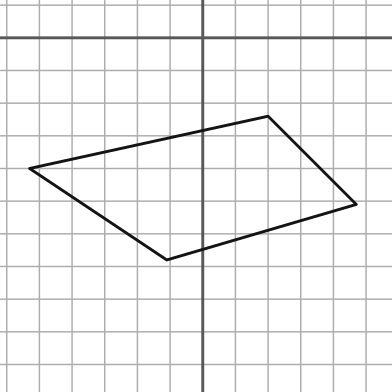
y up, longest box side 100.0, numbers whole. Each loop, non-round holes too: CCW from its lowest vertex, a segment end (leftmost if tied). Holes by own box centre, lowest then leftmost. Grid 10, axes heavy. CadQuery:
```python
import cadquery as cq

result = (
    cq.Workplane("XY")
    .moveTo(-11.0, -68.0)
    .lineTo(47.0, -51.0)
    .lineTo(20.0, -24.0)
    .lineTo(-53.0, -40.0)
    .close()
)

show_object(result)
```